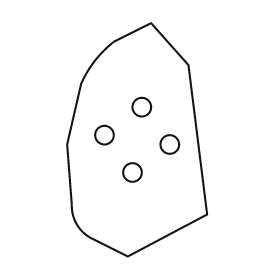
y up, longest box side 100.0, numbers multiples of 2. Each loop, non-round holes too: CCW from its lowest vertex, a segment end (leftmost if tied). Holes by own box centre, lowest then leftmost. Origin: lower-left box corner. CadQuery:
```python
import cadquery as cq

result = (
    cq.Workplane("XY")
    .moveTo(26.0, 0.0)
    .lineTo(60.0, 18.0)
    .lineTo(52.0, 82.0)
    .lineTo(36.0, 100.0)
    .lineTo(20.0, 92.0)
    .threePointArc((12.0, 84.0), (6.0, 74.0))
    .lineTo(0.0, 48.0)
    .lineTo(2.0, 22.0)
    .threePointArc((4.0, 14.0), (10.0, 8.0))
    .close()
    .moveTo(28.0, 36.0)
    .circle(4.0)
    .moveTo(44.0, 48.0)
    .circle(4.0)
    .moveTo(16.0, 52.0)
    .circle(4.0)
    .moveTo(32.0, 64.0)
    .circle(4.0)
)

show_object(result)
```